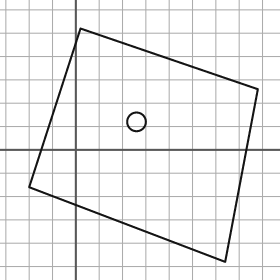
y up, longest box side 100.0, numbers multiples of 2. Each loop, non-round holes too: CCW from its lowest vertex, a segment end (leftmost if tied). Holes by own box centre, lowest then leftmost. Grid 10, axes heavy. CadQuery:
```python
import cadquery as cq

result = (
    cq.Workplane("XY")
    .moveTo(64.0, -48.0)
    .lineTo(78.0, 26.0)
    .lineTo(2.0, 52.0)
    .lineTo(-20.0, -16.0)
    .close()
    .moveTo(26.0, 12.0)
    .circle(4.0)
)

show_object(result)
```